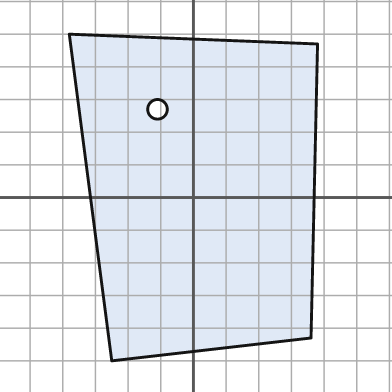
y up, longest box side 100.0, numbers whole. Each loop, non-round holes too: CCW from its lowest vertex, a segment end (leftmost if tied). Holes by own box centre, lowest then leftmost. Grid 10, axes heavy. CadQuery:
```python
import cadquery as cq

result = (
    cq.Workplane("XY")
    .moveTo(-25.0, -50.0)
    .lineTo(36.0, -43.0)
    .lineTo(38.0, 47.0)
    .lineTo(-38.0, 50.0)
    .close()
    .moveTo(-11.0, 27.0)
    .circle(3.0)
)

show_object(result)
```